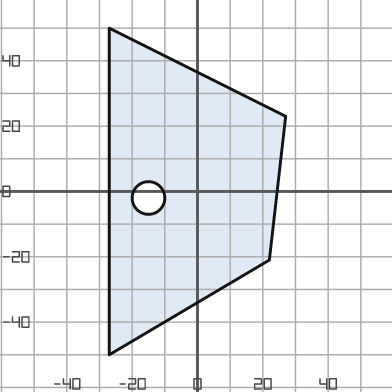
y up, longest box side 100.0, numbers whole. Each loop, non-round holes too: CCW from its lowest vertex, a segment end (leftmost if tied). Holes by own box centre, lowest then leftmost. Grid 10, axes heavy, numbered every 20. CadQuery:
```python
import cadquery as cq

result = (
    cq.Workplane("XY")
    .moveTo(-27.0, -50.0)
    .lineTo(22.0, -21.0)
    .lineTo(27.0, 23.0)
    .lineTo(-27.0, 50.0)
    .close()
    .moveTo(-15.0, -2.0)
    .circle(5.0)
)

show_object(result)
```